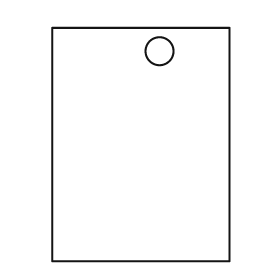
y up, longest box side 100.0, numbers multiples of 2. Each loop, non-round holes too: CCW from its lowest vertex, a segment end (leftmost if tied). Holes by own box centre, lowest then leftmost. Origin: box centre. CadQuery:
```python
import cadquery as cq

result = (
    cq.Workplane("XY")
    .moveTo(-38.0, -50.0)
    .lineTo(38.0, -50.0)
    .lineTo(38.0, 50.0)
    .lineTo(-38.0, 50.0)
    .close()
    .moveTo(8.0, 40.0)
    .circle(6.0)
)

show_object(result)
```